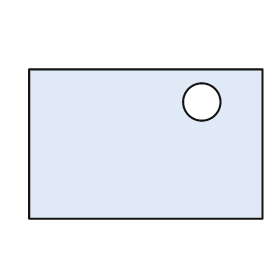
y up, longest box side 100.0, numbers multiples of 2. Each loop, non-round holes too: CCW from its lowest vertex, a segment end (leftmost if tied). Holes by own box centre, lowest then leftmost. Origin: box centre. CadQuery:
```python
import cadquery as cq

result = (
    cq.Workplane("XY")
    .moveTo(-50.0, -32.0)
    .lineTo(50.0, -32.0)
    .lineTo(50.0, 32.0)
    .lineTo(-50.0, 32.0)
    .close()
    .moveTo(24.0, 18.0)
    .circle(8.0)
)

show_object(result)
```